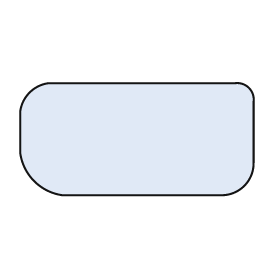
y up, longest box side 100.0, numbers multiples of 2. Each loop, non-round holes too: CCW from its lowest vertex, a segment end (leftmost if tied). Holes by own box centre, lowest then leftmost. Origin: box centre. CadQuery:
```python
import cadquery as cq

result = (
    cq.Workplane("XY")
    .moveTo(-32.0, -24.0)
    .lineTo(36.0, -24.0)
    .threePointArc((46.0, -20.0), (50.0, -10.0))
    .lineTo(50.0, 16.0)
    .threePointArc((48.0, 22.0), (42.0, 24.0))
    .lineTo(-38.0, 24.0)
    .threePointArc((-46.0, 20.0), (-50.0, 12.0))
    .lineTo(-50.0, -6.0)
    .threePointArc((-44.0, -18.0), (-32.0, -24.0))
    .close()
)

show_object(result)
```